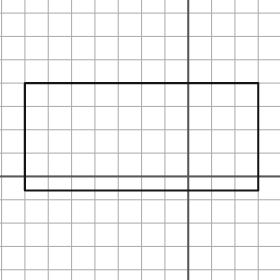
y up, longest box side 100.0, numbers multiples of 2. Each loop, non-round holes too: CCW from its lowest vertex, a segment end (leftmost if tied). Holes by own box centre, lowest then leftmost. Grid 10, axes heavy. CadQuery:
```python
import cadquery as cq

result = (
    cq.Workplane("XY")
    .moveTo(-70.0, -6.0)
    .lineTo(30.0, -6.0)
    .lineTo(30.0, 40.0)
    .lineTo(-70.0, 40.0)
    .close()
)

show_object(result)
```